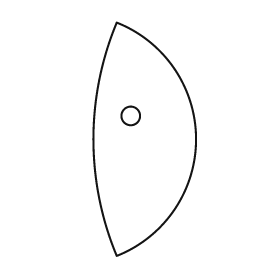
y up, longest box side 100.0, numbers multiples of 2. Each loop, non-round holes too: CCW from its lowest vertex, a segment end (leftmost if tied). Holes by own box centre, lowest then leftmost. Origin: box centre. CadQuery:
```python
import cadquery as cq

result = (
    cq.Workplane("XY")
    .moveTo(-12.0, -50.0)
    .threePointArc((22.0, 0.0), (-12.0, 50.0))
    .threePointArc((-22.0, 0.0), (-12.0, -50.0))
    .close()
    .moveTo(-6.0, 10.0)
    .circle(4.0)
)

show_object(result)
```